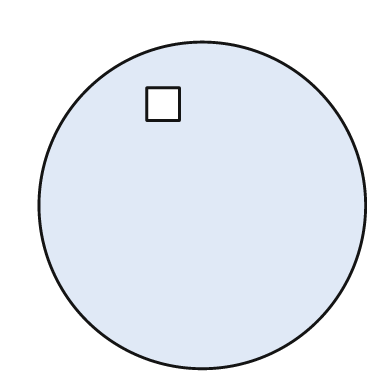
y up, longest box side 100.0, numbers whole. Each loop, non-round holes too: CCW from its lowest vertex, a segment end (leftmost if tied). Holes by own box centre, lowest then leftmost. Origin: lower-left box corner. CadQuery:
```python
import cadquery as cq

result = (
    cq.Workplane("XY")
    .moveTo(50.0, 50.0)
    .circle(50.0)
    .moveTo(33.0, 76.0)
    .lineTo(43.0, 76.0)
    .lineTo(43.0, 86.0)
    .lineTo(33.0, 86.0)
    .close()
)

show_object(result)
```